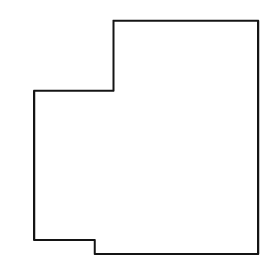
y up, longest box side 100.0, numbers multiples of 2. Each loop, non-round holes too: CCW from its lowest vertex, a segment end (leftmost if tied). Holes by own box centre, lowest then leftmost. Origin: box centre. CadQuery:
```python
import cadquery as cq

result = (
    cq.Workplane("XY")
    .moveTo(-22.0, -50.0)
    .lineTo(48.0, -50.0)
    .lineTo(48.0, 50.0)
    .lineTo(-14.0, 50.0)
    .lineTo(-14.0, 20.0)
    .lineTo(-48.0, 20.0)
    .lineTo(-48.0, -44.0)
    .lineTo(-22.0, -44.0)
    .close()
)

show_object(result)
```